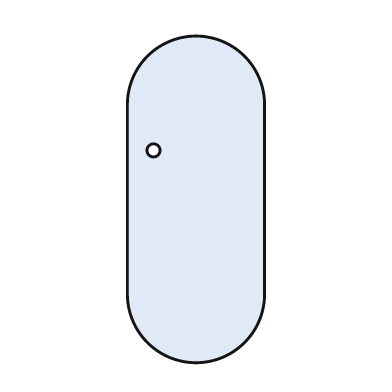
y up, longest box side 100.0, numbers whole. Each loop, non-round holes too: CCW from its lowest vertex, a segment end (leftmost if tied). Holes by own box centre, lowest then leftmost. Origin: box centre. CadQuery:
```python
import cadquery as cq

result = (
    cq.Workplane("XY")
    .moveTo(-21.0, -29.0)
    .threePointArc((0.0, -50.0), (21.0, -29.0))
    .lineTo(21.0, 29.0)
    .threePointArc((0.0, 50.0), (-21.0, 29.0))
    .close()
    .moveTo(-13.0, 15.0)
    .circle(2.0)
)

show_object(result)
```